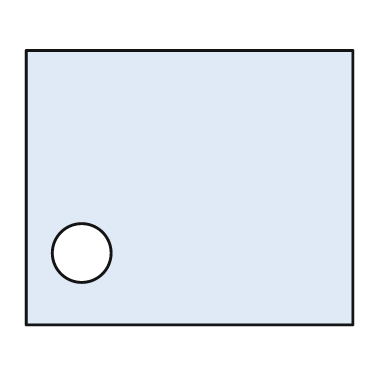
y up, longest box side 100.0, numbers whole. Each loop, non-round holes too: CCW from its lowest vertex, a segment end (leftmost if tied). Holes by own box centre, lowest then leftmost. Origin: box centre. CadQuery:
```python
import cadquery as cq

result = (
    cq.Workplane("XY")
    .moveTo(-50.0, -42.0)
    .lineTo(50.0, -42.0)
    .lineTo(50.0, 42.0)
    .lineTo(-50.0, 42.0)
    .close()
    .moveTo(-33.0, -20.0)
    .circle(9.0)
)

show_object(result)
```